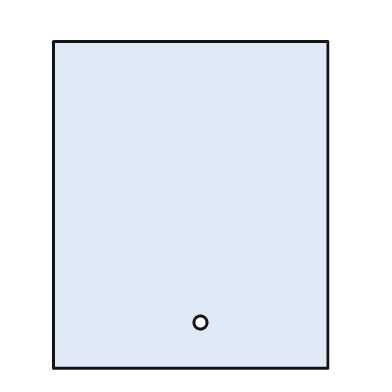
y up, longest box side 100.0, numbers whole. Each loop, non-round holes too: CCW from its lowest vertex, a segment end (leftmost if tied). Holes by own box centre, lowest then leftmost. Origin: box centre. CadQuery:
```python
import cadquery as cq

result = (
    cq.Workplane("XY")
    .moveTo(-42.0, -50.0)
    .lineTo(42.0, -50.0)
    .lineTo(42.0, 50.0)
    .lineTo(-42.0, 50.0)
    .close()
    .moveTo(3.0, -36.0)
    .circle(2.0)
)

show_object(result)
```